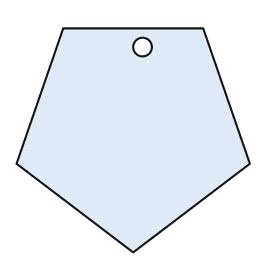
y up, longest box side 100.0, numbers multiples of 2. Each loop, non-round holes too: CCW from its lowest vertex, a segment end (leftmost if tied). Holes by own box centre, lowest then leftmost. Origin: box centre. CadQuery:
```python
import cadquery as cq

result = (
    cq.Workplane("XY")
    .moveTo(0.0, -48.0)
    .lineTo(50.0, -10.0)
    .lineTo(30.0, 48.0)
    .lineTo(-30.0, 48.0)
    .lineTo(-50.0, -10.0)
    .close()
    .moveTo(4.0, 40.0)
    .circle(4.0)
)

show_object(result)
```